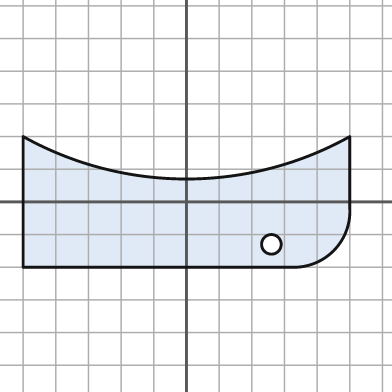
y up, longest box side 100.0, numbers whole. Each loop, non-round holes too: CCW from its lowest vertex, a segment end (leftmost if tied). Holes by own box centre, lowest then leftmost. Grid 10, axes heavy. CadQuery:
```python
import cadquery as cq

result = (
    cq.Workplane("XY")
    .moveTo(-50.0, -20.0)
    .lineTo(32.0, -20.0)
    .threePointArc((45.0, -15.0), (50.0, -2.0))
    .lineTo(50.0, 20.0)
    .threePointArc((0.0, 7.0), (-50.0, 20.0))
    .close()
    .moveTo(26.0, -13.0)
    .circle(3.0)
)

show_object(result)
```